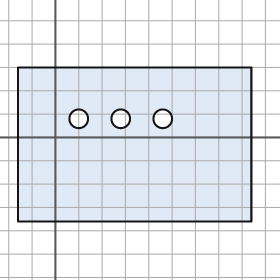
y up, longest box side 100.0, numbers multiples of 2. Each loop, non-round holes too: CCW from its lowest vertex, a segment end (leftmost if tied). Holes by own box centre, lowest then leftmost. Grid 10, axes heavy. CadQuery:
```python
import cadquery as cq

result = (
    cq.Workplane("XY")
    .moveTo(-16.0, -36.0)
    .lineTo(84.0, -36.0)
    .lineTo(84.0, 30.0)
    .lineTo(-16.0, 30.0)
    .close()
    .moveTo(10.0, 8.0)
    .circle(4.0)
    .moveTo(28.0, 8.0)
    .circle(4.0)
    .moveTo(46.0, 8.0)
    .circle(4.0)
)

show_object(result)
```